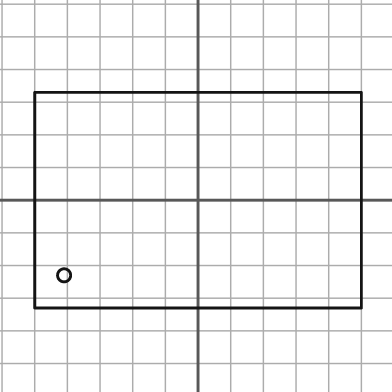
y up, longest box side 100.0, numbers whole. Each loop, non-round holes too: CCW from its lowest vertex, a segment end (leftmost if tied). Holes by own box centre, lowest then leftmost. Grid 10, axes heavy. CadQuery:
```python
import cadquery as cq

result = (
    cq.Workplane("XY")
    .moveTo(-50.0, -33.0)
    .lineTo(50.0, -33.0)
    .lineTo(50.0, 33.0)
    .lineTo(-50.0, 33.0)
    .close()
    .moveTo(-41.0, -23.0)
    .circle(2.0)
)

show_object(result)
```